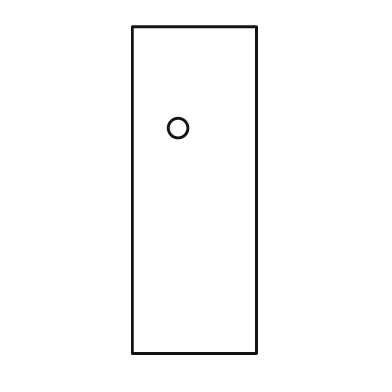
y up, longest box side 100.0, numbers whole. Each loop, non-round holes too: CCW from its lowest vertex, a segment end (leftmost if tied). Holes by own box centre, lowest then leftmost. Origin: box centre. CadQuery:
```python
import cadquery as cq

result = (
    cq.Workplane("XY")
    .moveTo(-19.0, -50.0)
    .lineTo(19.0, -50.0)
    .lineTo(19.0, 50.0)
    .lineTo(-19.0, 50.0)
    .close()
    .moveTo(-5.0, 19.0)
    .circle(3.0)
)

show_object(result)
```